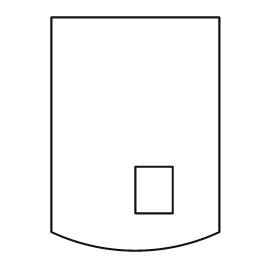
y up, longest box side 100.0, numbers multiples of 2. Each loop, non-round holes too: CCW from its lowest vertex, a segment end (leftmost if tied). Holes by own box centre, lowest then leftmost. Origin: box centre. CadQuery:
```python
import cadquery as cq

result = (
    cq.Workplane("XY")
    .moveTo(-36.0, -42.0)
    .threePointArc((0.0, -50.0), (36.0, -42.0))
    .lineTo(36.0, 50.0)
    .lineTo(-36.0, 50.0)
    .close()
    .moveTo(0.0, -34.0)
    .lineTo(16.0, -34.0)
    .lineTo(16.0, -14.0)
    .lineTo(0.0, -14.0)
    .close()
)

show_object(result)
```